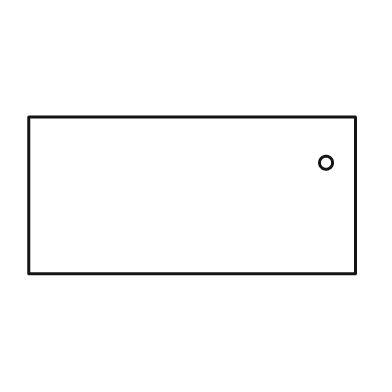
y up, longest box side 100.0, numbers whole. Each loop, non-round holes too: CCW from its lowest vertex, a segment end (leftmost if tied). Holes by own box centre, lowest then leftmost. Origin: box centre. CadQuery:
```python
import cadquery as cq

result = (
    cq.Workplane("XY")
    .moveTo(-50.0, -24.0)
    .lineTo(50.0, -24.0)
    .lineTo(50.0, 24.0)
    .lineTo(-50.0, 24.0)
    .close()
    .moveTo(41.0, 10.0)
    .circle(2.0)
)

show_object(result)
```